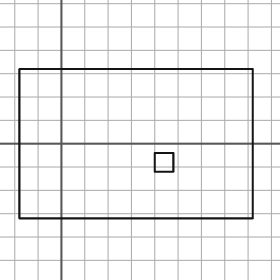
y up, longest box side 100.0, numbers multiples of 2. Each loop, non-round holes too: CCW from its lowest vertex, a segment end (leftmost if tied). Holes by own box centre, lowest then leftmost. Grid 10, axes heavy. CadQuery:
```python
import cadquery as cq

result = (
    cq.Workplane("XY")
    .moveTo(-18.0, -32.0)
    .lineTo(82.0, -32.0)
    .lineTo(82.0, 32.0)
    .lineTo(-18.0, 32.0)
    .close()
    .moveTo(40.0, -12.0)
    .lineTo(48.0, -12.0)
    .lineTo(48.0, -4.0)
    .lineTo(40.0, -4.0)
    .close()
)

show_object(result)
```